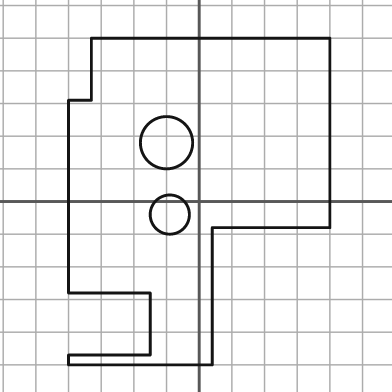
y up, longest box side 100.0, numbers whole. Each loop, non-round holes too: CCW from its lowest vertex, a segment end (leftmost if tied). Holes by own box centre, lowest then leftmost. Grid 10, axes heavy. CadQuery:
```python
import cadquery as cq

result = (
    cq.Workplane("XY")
    .moveTo(-40.0, -50.0)
    .lineTo(4.0, -50.0)
    .lineTo(4.0, -8.0)
    .lineTo(40.0, -8.0)
    .lineTo(40.0, 50.0)
    .lineTo(-33.0, 50.0)
    .lineTo(-33.0, 31.0)
    .lineTo(-40.0, 31.0)
    .lineTo(-40.0, -28.0)
    .lineTo(-15.0, -28.0)
    .lineTo(-15.0, -47.0)
    .lineTo(-40.0, -47.0)
    .close()
    .moveTo(-9.0, -4.0)
    .circle(6.0)
    .moveTo(-10.0, 18.0)
    .circle(8.0)
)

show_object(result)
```